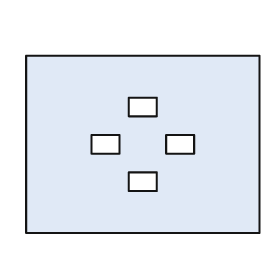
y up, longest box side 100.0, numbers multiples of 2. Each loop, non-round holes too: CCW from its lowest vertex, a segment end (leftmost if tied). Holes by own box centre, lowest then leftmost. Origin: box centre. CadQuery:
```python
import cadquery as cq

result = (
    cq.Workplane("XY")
    .moveTo(-50.0, -38.0)
    .lineTo(50.0, -38.0)
    .lineTo(50.0, 38.0)
    .lineTo(-50.0, 38.0)
    .close()
    .moveTo(-6.0, -20.0)
    .lineTo(6.0, -20.0)
    .lineTo(6.0, -12.0)
    .lineTo(-6.0, -12.0)
    .close()
    .moveTo(-22.0, -4.0)
    .lineTo(-10.0, -4.0)
    .lineTo(-10.0, 4.0)
    .lineTo(-22.0, 4.0)
    .close()
    .moveTo(10.0, -4.0)
    .lineTo(22.0, -4.0)
    .lineTo(22.0, 4.0)
    .lineTo(10.0, 4.0)
    .close()
    .moveTo(-6.0, 12.0)
    .lineTo(6.0, 12.0)
    .lineTo(6.0, 20.0)
    .lineTo(-6.0, 20.0)
    .close()
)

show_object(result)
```